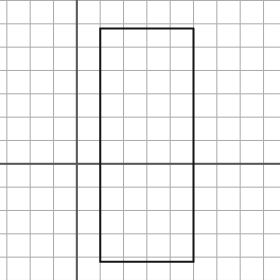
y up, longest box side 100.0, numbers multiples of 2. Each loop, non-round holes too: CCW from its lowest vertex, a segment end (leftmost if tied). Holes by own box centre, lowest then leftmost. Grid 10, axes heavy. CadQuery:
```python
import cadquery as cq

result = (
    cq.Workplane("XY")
    .moveTo(10.0, -42.0)
    .lineTo(50.0, -42.0)
    .lineTo(50.0, 58.0)
    .lineTo(10.0, 58.0)
    .close()
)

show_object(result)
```